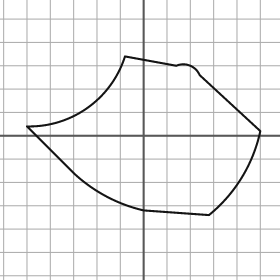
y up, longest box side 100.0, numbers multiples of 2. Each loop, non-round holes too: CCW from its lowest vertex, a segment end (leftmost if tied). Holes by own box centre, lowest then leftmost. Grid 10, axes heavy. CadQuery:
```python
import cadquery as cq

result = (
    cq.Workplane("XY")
    .moveTo(28.0, -34.0)
    .threePointArc((42.0, -18.0), (50.0, 2.0))
    .lineTo(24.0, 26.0)
    .threePointArc((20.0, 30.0), (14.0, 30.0))
    .lineTo(-8.0, 34.0)
    .threePointArc((-24.0, 12.0), (-50.0, 4.0))
    .lineTo(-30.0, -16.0)
    .threePointArc((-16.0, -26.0), (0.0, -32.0))
    .close()
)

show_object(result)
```